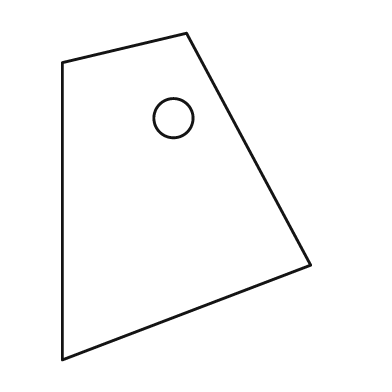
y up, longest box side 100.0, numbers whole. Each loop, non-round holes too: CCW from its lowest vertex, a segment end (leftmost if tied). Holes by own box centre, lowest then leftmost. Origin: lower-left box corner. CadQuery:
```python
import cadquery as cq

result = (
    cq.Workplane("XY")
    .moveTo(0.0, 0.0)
    .lineTo(76.0, 29.0)
    .lineTo(38.0, 100.0)
    .lineTo(0.0, 91.0)
    .close()
    .moveTo(34.0, 74.0)
    .circle(6.0)
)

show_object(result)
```